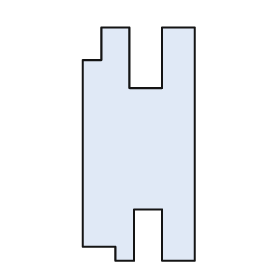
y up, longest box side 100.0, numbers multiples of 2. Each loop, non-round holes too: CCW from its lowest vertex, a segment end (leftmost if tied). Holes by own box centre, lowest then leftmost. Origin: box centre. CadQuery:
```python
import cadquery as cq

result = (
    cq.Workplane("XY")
    .moveTo(-10.0, -50.0)
    .lineTo(-2.0, -50.0)
    .lineTo(-2.0, -28.0)
    .lineTo(10.0, -28.0)
    .lineTo(10.0, -50.0)
    .lineTo(24.0, -50.0)
    .lineTo(24.0, 50.0)
    .lineTo(10.0, 50.0)
    .lineTo(10.0, 24.0)
    .lineTo(-4.0, 24.0)
    .lineTo(-4.0, 50.0)
    .lineTo(-16.0, 50.0)
    .lineTo(-16.0, 36.0)
    .lineTo(-24.0, 36.0)
    .lineTo(-24.0, -44.0)
    .lineTo(-10.0, -44.0)
    .close()
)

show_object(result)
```